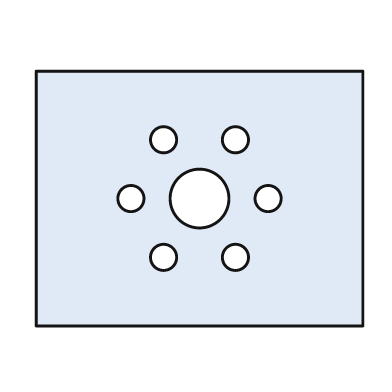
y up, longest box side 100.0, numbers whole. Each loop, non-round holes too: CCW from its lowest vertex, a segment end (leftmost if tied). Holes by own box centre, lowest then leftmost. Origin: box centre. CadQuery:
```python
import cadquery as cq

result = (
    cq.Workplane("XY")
    .moveTo(-50.0, -39.0)
    .lineTo(50.0, -39.0)
    .lineTo(50.0, 39.0)
    .lineTo(-50.0, 39.0)
    .close()
    .moveTo(-11.0, -18.0)
    .circle(4.0)
    .moveTo(11.0, -18.0)
    .circle(4.0)
    .moveTo(-21.0, 0.0)
    .circle(4.0)
    .moveTo(0.0, 0.0)
    .circle(9.0)
    .moveTo(21.0, 0.0)
    .circle(4.0)
    .moveTo(-11.0, 18.0)
    .circle(4.0)
    .moveTo(11.0, 18.0)
    .circle(4.0)
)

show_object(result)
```